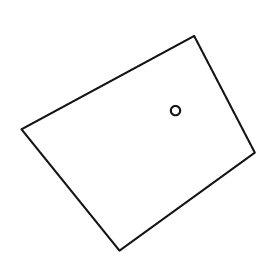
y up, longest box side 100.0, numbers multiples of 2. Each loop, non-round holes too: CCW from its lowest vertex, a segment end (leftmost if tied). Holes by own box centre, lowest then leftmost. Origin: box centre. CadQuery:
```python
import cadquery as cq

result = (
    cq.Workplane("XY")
    .moveTo(-8.0, -46.0)
    .lineTo(50.0, -4.0)
    .lineTo(24.0, 46.0)
    .lineTo(-50.0, 6.0)
    .close()
    .moveTo(16.0, 14.0)
    .circle(2.0)
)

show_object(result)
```